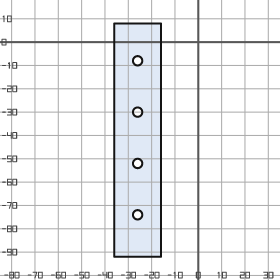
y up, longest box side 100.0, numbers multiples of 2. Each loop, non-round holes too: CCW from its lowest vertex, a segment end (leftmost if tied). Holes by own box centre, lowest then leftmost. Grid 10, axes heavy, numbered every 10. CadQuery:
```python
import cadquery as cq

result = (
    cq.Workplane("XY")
    .moveTo(-36.0, -92.0)
    .lineTo(-16.0, -92.0)
    .lineTo(-16.0, 8.0)
    .lineTo(-36.0, 8.0)
    .close()
    .moveTo(-26.0, -74.0)
    .circle(2.0)
    .moveTo(-26.0, -52.0)
    .circle(2.0)
    .moveTo(-26.0, -30.0)
    .circle(2.0)
    .moveTo(-26.0, -8.0)
    .circle(2.0)
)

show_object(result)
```